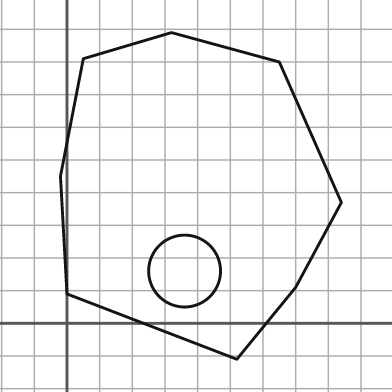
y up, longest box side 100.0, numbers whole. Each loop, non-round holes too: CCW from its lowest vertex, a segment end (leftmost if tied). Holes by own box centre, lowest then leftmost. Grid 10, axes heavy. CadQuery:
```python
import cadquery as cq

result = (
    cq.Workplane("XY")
    .moveTo(52.0, -11.0)
    .lineTo(70.0, 11.0)
    .lineTo(84.0, 37.0)
    .lineTo(65.0, 80.0)
    .lineTo(32.0, 89.0)
    .lineTo(5.0, 81.0)
    .lineTo(-2.0, 45.0)
    .lineTo(0.0, 9.0)
    .close()
    .moveTo(36.0, 16.0)
    .circle(11.0)
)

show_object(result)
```